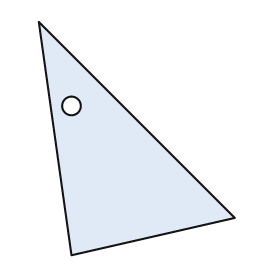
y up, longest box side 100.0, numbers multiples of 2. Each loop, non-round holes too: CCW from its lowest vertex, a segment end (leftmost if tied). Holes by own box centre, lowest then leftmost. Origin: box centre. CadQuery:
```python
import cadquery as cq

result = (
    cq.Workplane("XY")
    .moveTo(-28.0, -50.0)
    .lineTo(42.0, -34.0)
    .lineTo(-42.0, 50.0)
    .close()
    .moveTo(-28.0, 14.0)
    .circle(4.0)
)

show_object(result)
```